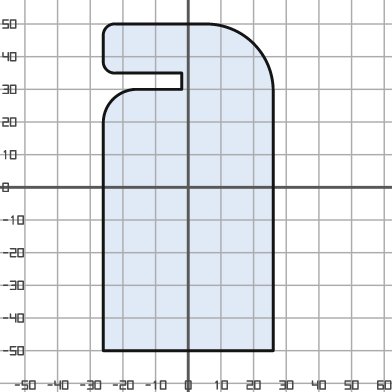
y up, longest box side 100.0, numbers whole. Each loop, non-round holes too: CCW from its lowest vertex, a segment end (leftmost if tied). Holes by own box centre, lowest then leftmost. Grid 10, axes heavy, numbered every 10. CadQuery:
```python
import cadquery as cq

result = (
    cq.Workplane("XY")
    .moveTo(-26.0, -50.0)
    .lineTo(26.0, -50.0)
    .lineTo(26.0, 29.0)
    .threePointArc((20.0, 44.0), (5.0, 50.0))
    .lineTo(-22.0, 50.0)
    .threePointArc((-25.0, 49.0), (-26.0, 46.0))
    .lineTo(-26.0, 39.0)
    .threePointArc((-25.0, 36.0), (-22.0, 35.0))
    .lineTo(-2.0, 35.0)
    .lineTo(-2.0, 30.0)
    .lineTo(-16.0, 30.0)
    .threePointArc((-23.0, 27.0), (-26.0, 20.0))
    .close()
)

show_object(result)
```